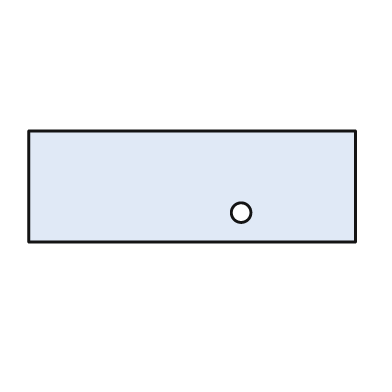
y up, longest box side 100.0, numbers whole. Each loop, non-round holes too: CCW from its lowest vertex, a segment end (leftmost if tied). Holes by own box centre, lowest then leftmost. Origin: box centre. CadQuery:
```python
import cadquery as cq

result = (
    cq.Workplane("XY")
    .moveTo(-50.0, -17.0)
    .lineTo(50.0, -17.0)
    .lineTo(50.0, 17.0)
    .lineTo(-50.0, 17.0)
    .close()
    .moveTo(15.0, -8.0)
    .circle(3.0)
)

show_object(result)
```